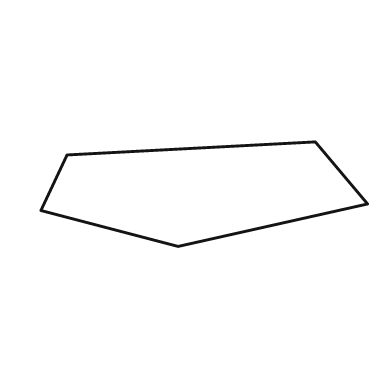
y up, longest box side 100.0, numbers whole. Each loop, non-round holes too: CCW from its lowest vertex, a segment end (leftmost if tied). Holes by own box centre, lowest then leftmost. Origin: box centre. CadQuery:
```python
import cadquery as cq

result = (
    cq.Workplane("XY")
    .moveTo(-8.0, -16.0)
    .lineTo(50.0, -3.0)
    .lineTo(34.0, 16.0)
    .lineTo(-42.0, 12.0)
    .lineTo(-50.0, -5.0)
    .close()
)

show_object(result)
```